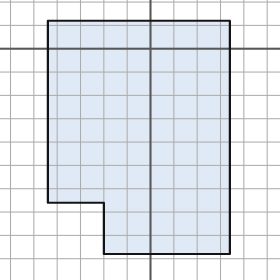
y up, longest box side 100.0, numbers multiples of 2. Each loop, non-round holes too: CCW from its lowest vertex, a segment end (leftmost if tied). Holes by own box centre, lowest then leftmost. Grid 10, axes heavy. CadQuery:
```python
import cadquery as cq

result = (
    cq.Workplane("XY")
    .moveTo(-20.0, -88.0)
    .lineTo(34.0, -88.0)
    .lineTo(34.0, 12.0)
    .lineTo(-44.0, 12.0)
    .lineTo(-44.0, -66.0)
    .lineTo(-20.0, -66.0)
    .close()
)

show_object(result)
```